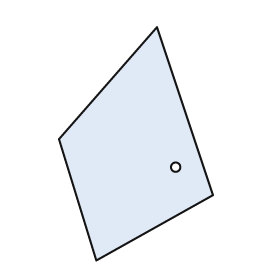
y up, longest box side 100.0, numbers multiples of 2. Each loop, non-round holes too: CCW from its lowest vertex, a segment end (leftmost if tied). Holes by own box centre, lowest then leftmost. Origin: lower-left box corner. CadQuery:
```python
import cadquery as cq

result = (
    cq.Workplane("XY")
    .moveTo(16.0, 0.0)
    .lineTo(66.0, 28.0)
    .lineTo(42.0, 100.0)
    .lineTo(0.0, 52.0)
    .close()
    .moveTo(50.0, 40.0)
    .circle(2.0)
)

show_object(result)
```